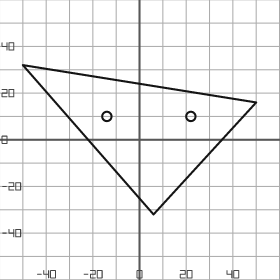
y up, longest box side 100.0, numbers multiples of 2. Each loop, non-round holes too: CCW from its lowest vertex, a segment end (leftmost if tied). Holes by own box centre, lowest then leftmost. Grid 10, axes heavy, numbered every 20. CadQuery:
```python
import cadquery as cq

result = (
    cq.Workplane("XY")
    .moveTo(6.0, -32.0)
    .lineTo(50.0, 16.0)
    .lineTo(-50.0, 32.0)
    .close()
    .moveTo(-14.0, 10.0)
    .circle(2.0)
    .moveTo(22.0, 10.0)
    .circle(2.0)
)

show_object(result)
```